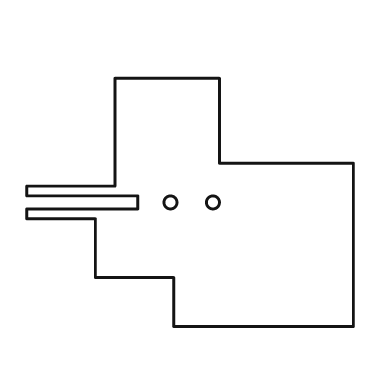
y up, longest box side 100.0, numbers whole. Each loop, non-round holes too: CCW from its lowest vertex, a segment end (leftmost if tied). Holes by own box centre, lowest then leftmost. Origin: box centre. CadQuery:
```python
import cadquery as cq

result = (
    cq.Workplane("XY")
    .moveTo(-5.0, -38.0)
    .lineTo(50.0, -38.0)
    .lineTo(50.0, 12.0)
    .lineTo(9.0, 12.0)
    .lineTo(9.0, 38.0)
    .lineTo(-23.0, 38.0)
    .lineTo(-23.0, 5.0)
    .lineTo(-50.0, 5.0)
    .lineTo(-50.0, 2.0)
    .lineTo(-16.0, 2.0)
    .lineTo(-16.0, -2.0)
    .lineTo(-50.0, -2.0)
    .lineTo(-50.0, -5.0)
    .lineTo(-29.0, -5.0)
    .lineTo(-29.0, -23.0)
    .lineTo(-5.0, -23.0)
    .close()
    .moveTo(-6.0, 0.0)
    .circle(2.0)
    .moveTo(7.0, 0.0)
    .circle(2.0)
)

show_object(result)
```